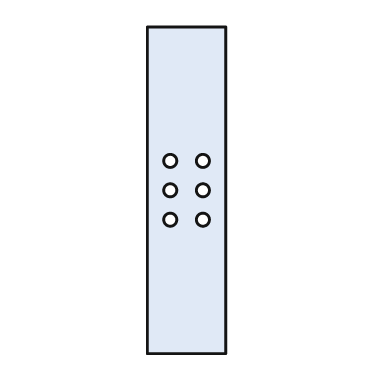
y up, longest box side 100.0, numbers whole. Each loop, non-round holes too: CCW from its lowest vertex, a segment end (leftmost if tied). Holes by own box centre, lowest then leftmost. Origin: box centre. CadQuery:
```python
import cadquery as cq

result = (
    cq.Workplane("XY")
    .moveTo(-12.0, -50.0)
    .lineTo(12.0, -50.0)
    .lineTo(12.0, 50.0)
    .lineTo(-12.0, 50.0)
    .close()
    .moveTo(-5.0, -9.0)
    .circle(2.0)
    .moveTo(5.0, -9.0)
    .circle(2.0)
    .moveTo(-5.0, 0.0)
    .circle(2.0)
    .moveTo(5.0, 0.0)
    .circle(2.0)
    .moveTo(-5.0, 9.0)
    .circle(2.0)
    .moveTo(5.0, 9.0)
    .circle(2.0)
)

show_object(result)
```